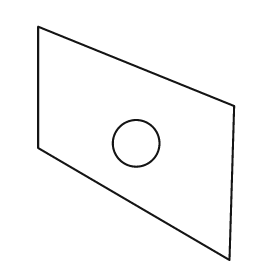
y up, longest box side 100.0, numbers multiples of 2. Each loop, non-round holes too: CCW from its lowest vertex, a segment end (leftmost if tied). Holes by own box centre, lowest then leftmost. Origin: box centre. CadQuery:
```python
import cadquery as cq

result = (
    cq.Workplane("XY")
    .moveTo(40.0, -50.0)
    .lineTo(42.0, 16.0)
    .lineTo(-42.0, 50.0)
    .lineTo(-42.0, -2.0)
    .close()
    .moveTo(0.0, 0.0)
    .circle(10.0)
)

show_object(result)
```